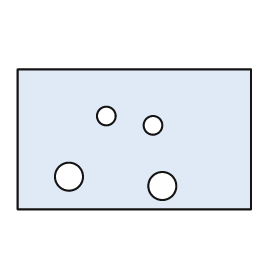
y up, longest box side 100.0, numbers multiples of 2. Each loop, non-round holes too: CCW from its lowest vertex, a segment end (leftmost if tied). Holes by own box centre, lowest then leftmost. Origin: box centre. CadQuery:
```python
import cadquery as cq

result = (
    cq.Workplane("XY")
    .moveTo(-50.0, -30.0)
    .lineTo(50.0, -30.0)
    .lineTo(50.0, 30.0)
    .lineTo(-50.0, 30.0)
    .close()
    .moveTo(12.0, -20.0)
    .circle(6.0)
    .moveTo(-28.0, -16.0)
    .circle(6.0)
    .moveTo(8.0, 6.0)
    .circle(4.0)
    .moveTo(-12.0, 10.0)
    .circle(4.0)
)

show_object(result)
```